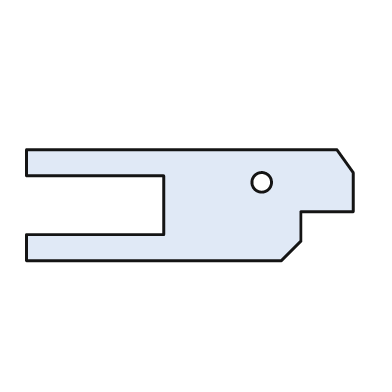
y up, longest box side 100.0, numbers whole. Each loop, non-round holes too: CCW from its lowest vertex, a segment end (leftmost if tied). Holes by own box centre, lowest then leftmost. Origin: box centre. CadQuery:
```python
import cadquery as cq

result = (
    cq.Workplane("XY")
    .moveTo(-50.0, -17.0)
    .lineTo(28.0, -17.0)
    .lineTo(34.0, -11.0)
    .lineTo(34.0, -2.0)
    .lineTo(50.0, -2.0)
    .lineTo(50.0, 10.0)
    .lineTo(45.0, 17.0)
    .lineTo(-50.0, 17.0)
    .lineTo(-50.0, 9.0)
    .lineTo(-8.0, 9.0)
    .lineTo(-8.0, -9.0)
    .lineTo(-50.0, -9.0)
    .close()
    .moveTo(22.0, 7.0)
    .circle(3.0)
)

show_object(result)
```